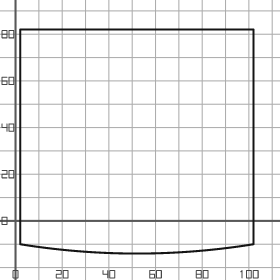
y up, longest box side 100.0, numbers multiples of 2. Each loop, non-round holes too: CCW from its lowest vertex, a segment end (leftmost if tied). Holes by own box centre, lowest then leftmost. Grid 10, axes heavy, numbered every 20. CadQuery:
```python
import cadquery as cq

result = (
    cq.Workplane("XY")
    .moveTo(2.0, -10.0)
    .threePointArc((52.0, -14.0), (102.0, -10.0))
    .lineTo(102.0, 82.0)
    .lineTo(2.0, 82.0)
    .close()
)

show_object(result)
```